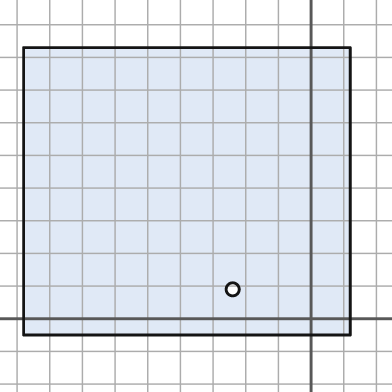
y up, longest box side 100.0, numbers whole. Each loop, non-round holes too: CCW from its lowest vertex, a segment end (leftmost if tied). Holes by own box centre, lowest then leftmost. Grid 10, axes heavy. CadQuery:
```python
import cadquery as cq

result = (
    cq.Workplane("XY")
    .moveTo(-88.0, -5.0)
    .lineTo(12.0, -5.0)
    .lineTo(12.0, 83.0)
    .lineTo(-88.0, 83.0)
    .close()
    .moveTo(-24.0, 9.0)
    .circle(2.0)
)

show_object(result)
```